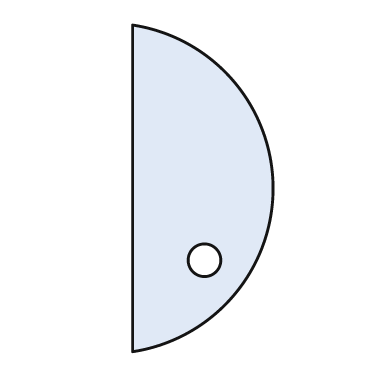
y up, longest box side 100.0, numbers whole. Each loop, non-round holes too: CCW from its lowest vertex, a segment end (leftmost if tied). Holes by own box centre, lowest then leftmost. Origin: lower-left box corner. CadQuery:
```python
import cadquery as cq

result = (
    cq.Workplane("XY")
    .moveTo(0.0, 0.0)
    .threePointArc((43.0, 50.0), (0.0, 100.0))
    .close()
    .moveTo(22.0, 28.0)
    .circle(5.0)
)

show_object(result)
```